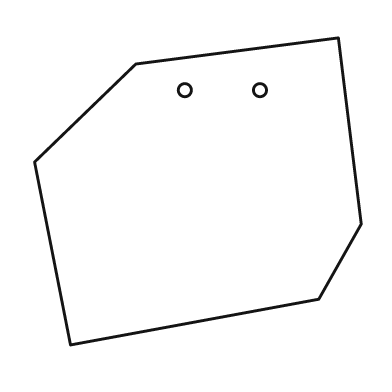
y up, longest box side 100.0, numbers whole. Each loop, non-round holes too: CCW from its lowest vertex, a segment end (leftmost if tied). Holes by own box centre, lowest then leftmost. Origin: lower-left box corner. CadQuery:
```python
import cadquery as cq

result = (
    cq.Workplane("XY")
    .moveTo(11.0, 0.0)
    .lineTo(87.0, 14.0)
    .lineTo(100.0, 37.0)
    .lineTo(93.0, 94.0)
    .lineTo(31.0, 86.0)
    .lineTo(0.0, 56.0)
    .close()
    .moveTo(46.0, 78.0)
    .circle(2.0)
    .moveTo(69.0, 78.0)
    .circle(2.0)
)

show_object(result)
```